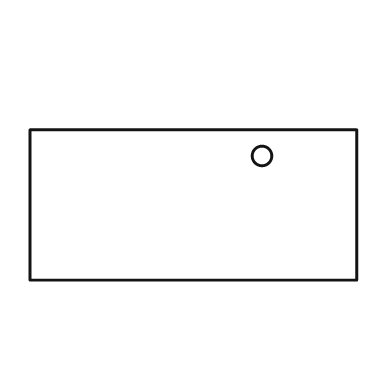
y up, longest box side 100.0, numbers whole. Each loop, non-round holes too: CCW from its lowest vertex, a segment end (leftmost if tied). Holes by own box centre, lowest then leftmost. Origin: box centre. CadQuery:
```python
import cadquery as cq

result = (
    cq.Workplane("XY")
    .moveTo(-50.0, -23.0)
    .lineTo(50.0, -23.0)
    .lineTo(50.0, 23.0)
    .lineTo(-50.0, 23.0)
    .close()
    .moveTo(21.0, 15.0)
    .circle(3.0)
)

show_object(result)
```